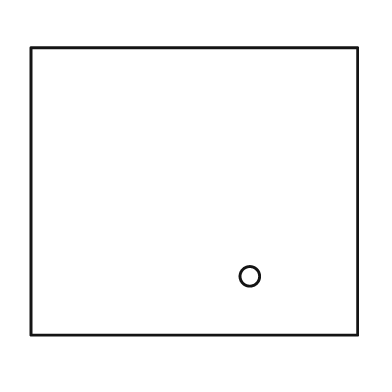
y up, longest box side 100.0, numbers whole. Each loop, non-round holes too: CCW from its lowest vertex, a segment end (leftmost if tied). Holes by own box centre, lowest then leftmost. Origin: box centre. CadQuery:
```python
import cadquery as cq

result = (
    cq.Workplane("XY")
    .moveTo(-50.0, -44.0)
    .lineTo(50.0, -44.0)
    .lineTo(50.0, 44.0)
    .lineTo(-50.0, 44.0)
    .close()
    .moveTo(17.0, -26.0)
    .circle(3.0)
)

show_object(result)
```